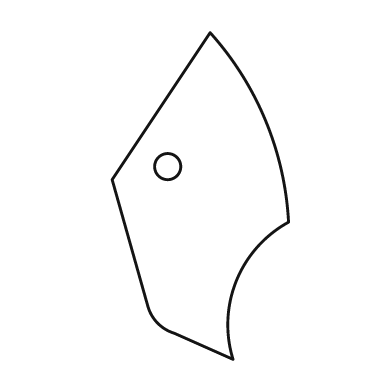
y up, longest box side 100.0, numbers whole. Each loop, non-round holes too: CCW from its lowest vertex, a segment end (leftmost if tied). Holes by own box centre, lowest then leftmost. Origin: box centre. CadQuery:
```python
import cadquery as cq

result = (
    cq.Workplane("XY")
    .moveTo(10.0, -50.0)
    .threePointArc((11.0, -26.0), (27.0, -8.0))
    .threePointArc((20.0, 23.0), (3.0, 50.0))
    .lineTo(-27.0, 5.0)
    .lineTo(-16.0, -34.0)
    .threePointArc((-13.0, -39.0), (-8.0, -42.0))
    .close()
    .moveTo(-10.0, 9.0)
    .circle(4.0)
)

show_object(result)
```